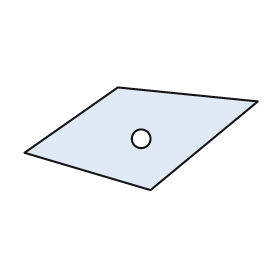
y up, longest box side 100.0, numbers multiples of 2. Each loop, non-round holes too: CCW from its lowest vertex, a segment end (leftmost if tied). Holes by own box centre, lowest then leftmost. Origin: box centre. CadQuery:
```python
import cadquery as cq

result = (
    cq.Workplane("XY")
    .moveTo(4.0, -22.0)
    .lineTo(50.0, 16.0)
    .lineTo(-10.0, 22.0)
    .lineTo(-50.0, -6.0)
    .close()
    .moveTo(0.0, 0.0)
    .circle(4.0)
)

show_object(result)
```